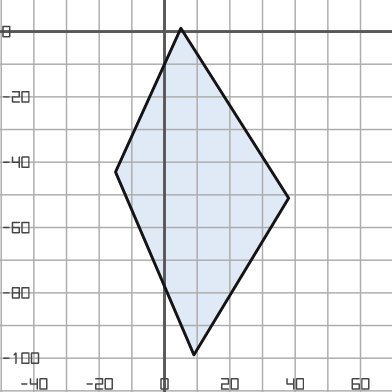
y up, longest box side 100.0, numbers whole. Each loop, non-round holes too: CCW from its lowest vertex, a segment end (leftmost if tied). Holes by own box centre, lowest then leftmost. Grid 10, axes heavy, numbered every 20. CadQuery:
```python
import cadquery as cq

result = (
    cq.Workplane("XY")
    .moveTo(9.0, -99.0)
    .lineTo(38.0, -51.0)
    .lineTo(5.0, 1.0)
    .lineTo(-15.0, -43.0)
    .close()
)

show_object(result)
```